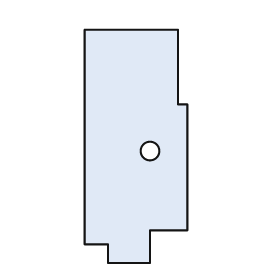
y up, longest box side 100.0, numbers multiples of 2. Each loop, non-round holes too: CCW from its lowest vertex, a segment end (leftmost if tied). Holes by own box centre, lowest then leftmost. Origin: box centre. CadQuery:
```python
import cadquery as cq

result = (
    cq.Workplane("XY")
    .moveTo(-12.0, -50.0)
    .lineTo(6.0, -50.0)
    .lineTo(6.0, -36.0)
    .lineTo(22.0, -36.0)
    .lineTo(22.0, 18.0)
    .lineTo(18.0, 18.0)
    .lineTo(18.0, 50.0)
    .lineTo(-22.0, 50.0)
    .lineTo(-22.0, -42.0)
    .lineTo(-12.0, -42.0)
    .close()
    .moveTo(6.0, -2.0)
    .circle(4.0)
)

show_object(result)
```